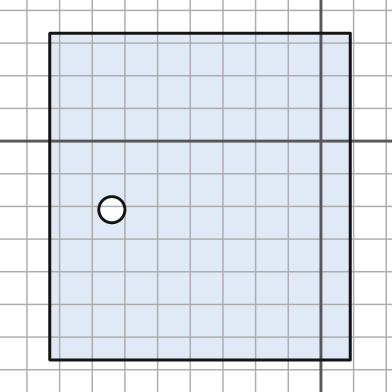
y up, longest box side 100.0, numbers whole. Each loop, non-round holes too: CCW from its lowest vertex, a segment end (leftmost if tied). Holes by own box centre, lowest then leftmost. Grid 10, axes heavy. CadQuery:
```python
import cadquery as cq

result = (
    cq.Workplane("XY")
    .moveTo(-83.0, -67.0)
    .lineTo(9.0, -67.0)
    .lineTo(9.0, 33.0)
    .lineTo(-83.0, 33.0)
    .close()
    .moveTo(-64.0, -21.0)
    .circle(4.0)
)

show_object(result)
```